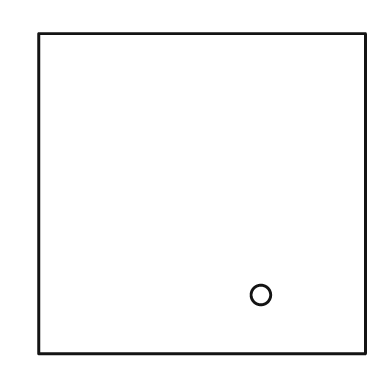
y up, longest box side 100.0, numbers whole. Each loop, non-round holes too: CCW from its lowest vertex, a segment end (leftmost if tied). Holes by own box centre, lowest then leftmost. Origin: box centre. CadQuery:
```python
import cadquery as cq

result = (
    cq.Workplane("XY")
    .moveTo(-50.0, -49.0)
    .lineTo(50.0, -49.0)
    .lineTo(50.0, 49.0)
    .lineTo(-50.0, 49.0)
    .close()
    .moveTo(18.0, -31.0)
    .circle(3.0)
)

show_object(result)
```